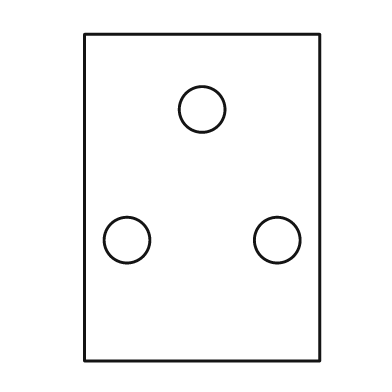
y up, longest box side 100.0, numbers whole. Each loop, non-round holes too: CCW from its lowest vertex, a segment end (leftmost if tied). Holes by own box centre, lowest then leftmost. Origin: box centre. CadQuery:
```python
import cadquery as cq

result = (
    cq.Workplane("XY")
    .moveTo(-36.0, -50.0)
    .lineTo(36.0, -50.0)
    .lineTo(36.0, 50.0)
    .lineTo(-36.0, 50.0)
    .close()
    .moveTo(-23.0, -13.0)
    .circle(7.0)
    .moveTo(23.0, -13.0)
    .circle(7.0)
    .moveTo(0.0, 27.0)
    .circle(7.0)
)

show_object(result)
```